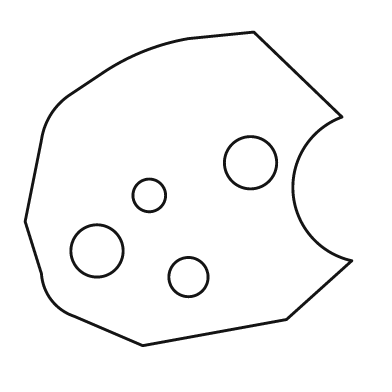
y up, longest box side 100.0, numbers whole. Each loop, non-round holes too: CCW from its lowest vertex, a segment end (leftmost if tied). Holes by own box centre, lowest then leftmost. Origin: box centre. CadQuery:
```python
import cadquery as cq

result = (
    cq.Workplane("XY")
    .moveTo(-14.0, -48.0)
    .lineTo(30.0, -40.0)
    .lineTo(50.0, -22.0)
    .threePointArc((32.0, -1.0), (47.0, 22.0))
    .lineTo(20.0, 48.0)
    .lineTo(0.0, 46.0)
    .threePointArc((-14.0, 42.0), (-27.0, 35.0))
    .lineTo(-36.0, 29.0)
    .threePointArc((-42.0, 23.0), (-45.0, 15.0))
    .lineTo(-50.0, -10.0)
    .lineTo(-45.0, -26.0)
    .threePointArc((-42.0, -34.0), (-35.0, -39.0))
    .close()
    .moveTo(0.0, -27.0)
    .circle(6.0)
    .moveTo(-28.0, -19.0)
    .circle(8.0)
    .moveTo(-12.0, -2.0)
    .circle(5.0)
    .moveTo(19.0, 8.0)
    .circle(8.0)
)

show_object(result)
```